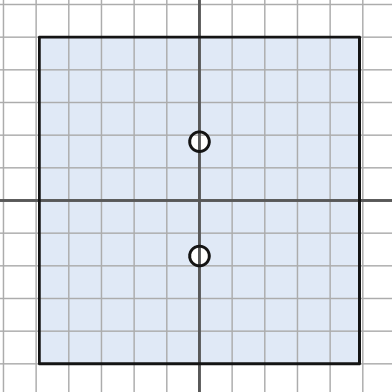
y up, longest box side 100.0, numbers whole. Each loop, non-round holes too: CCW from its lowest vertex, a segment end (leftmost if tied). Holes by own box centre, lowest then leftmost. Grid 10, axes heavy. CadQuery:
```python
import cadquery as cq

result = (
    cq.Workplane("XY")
    .moveTo(-49.0, -50.0)
    .lineTo(49.0, -50.0)
    .lineTo(49.0, 50.0)
    .lineTo(-49.0, 50.0)
    .close()
    .moveTo(0.0, -17.0)
    .circle(3.0)
    .moveTo(0.0, 18.0)
    .circle(3.0)
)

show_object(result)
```